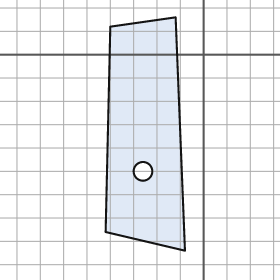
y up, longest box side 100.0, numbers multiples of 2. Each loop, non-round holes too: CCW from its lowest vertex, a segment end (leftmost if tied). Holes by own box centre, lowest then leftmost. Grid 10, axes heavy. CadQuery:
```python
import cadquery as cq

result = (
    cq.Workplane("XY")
    .moveTo(-8.0, -84.0)
    .lineTo(-12.0, 16.0)
    .lineTo(-40.0, 12.0)
    .lineTo(-42.0, -76.0)
    .close()
    .moveTo(-26.0, -50.0)
    .circle(4.0)
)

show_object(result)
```